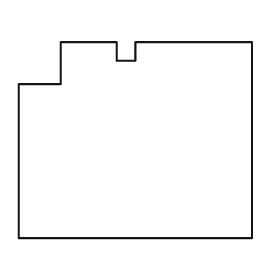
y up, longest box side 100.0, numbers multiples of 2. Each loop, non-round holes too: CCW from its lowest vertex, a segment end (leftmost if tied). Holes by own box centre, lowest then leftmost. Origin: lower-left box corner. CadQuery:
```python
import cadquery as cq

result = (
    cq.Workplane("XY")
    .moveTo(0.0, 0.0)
    .lineTo(100.0, 0.0)
    .lineTo(100.0, 84.0)
    .lineTo(50.0, 84.0)
    .lineTo(50.0, 76.0)
    .lineTo(42.0, 76.0)
    .lineTo(42.0, 84.0)
    .lineTo(18.0, 84.0)
    .lineTo(18.0, 66.0)
    .lineTo(0.0, 66.0)
    .close()
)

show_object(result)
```